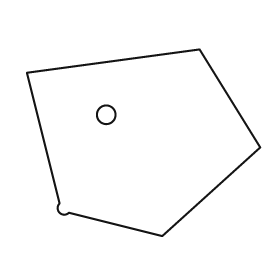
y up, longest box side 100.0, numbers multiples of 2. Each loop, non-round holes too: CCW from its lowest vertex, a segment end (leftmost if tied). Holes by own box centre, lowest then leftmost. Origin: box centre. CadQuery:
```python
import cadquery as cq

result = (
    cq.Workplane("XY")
    .moveTo(8.0, -40.0)
    .lineTo(50.0, -2.0)
    .lineTo(24.0, 40.0)
    .lineTo(-50.0, 30.0)
    .lineTo(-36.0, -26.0)
    .threePointArc((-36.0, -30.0), (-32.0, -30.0))
    .close()
    .moveTo(-16.0, 12.0)
    .circle(4.0)
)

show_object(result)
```